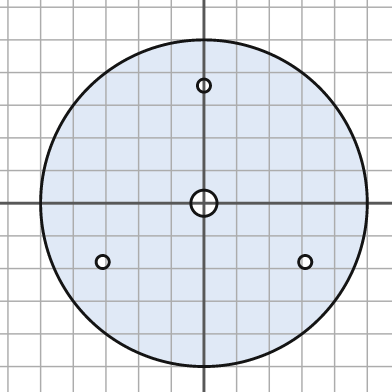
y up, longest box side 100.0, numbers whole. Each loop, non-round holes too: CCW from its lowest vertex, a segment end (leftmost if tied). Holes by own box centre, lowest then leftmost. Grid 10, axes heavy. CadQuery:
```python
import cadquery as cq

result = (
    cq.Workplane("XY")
    .moveTo(0.0, 0.0)
    .circle(50.0)
    .moveTo(-31.0, -18.0)
    .circle(2.0)
    .moveTo(31.0, -18.0)
    .circle(2.0)
    .moveTo(0.0, 0.0)
    .circle(4.0)
    .moveTo(0.0, 36.0)
    .circle(2.0)
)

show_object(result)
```